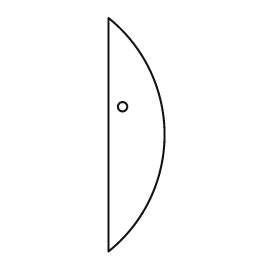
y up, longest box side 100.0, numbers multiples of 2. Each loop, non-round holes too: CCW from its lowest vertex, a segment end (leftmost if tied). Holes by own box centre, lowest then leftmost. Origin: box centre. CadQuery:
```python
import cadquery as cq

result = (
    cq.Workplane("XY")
    .moveTo(-12.0, -50.0)
    .threePointArc((12.0, 0.0), (-12.0, 50.0))
    .close()
    .moveTo(-6.0, 12.0)
    .circle(2.0)
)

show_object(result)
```